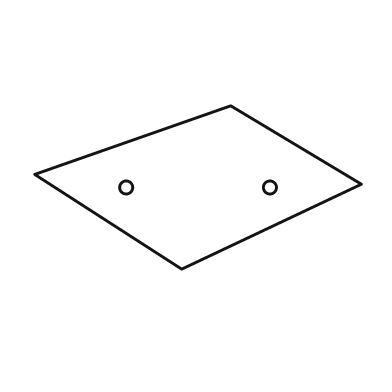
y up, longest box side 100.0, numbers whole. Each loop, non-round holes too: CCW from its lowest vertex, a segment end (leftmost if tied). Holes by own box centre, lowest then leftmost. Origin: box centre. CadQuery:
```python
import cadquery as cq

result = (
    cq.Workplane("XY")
    .moveTo(-5.0, -25.0)
    .lineTo(50.0, 1.0)
    .lineTo(10.0, 25.0)
    .lineTo(-50.0, 4.0)
    .close()
    .moveTo(-22.0, 0.0)
    .circle(2.0)
    .moveTo(22.0, 0.0)
    .circle(2.0)
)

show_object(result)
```